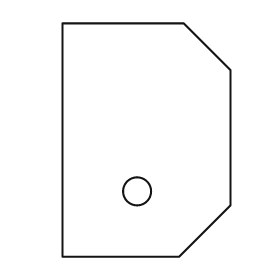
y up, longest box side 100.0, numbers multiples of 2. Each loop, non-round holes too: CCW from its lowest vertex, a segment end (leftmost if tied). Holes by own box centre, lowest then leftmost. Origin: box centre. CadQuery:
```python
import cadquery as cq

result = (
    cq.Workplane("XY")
    .moveTo(-36.0, -50.0)
    .lineTo(14.0, -50.0)
    .lineTo(36.0, -28.0)
    .lineTo(36.0, 30.0)
    .lineTo(16.0, 50.0)
    .lineTo(-36.0, 50.0)
    .close()
    .moveTo(-4.0, -22.0)
    .circle(6.0)
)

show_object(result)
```